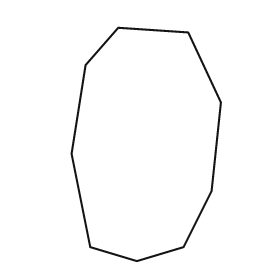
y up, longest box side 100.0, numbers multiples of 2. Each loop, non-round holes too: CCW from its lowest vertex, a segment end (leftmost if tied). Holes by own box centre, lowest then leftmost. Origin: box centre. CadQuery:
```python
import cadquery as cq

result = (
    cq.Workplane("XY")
    .moveTo(-4.0, -50.0)
    .lineTo(16.0, -44.0)
    .lineTo(28.0, -20.0)
    .lineTo(32.0, 18.0)
    .lineTo(18.0, 48.0)
    .lineTo(-12.0, 50.0)
    .lineTo(-26.0, 34.0)
    .lineTo(-32.0, -4.0)
    .lineTo(-24.0, -44.0)
    .close()
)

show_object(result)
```